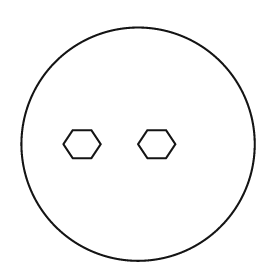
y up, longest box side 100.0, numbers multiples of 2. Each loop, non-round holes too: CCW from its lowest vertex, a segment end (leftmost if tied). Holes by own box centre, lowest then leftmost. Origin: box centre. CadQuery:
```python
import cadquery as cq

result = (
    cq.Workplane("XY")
    .moveTo(0.0, 0.0)
    .circle(50.0)
    .moveTo(-28.0, -6.0)
    .lineTo(-20.0, -6.0)
    .lineTo(-16.0, 0.0)
    .lineTo(-20.0, 6.0)
    .lineTo(-28.0, 6.0)
    .lineTo(-32.0, 0.0)
    .close()
    .moveTo(4.0, -6.0)
    .lineTo(12.0, -6.0)
    .lineTo(16.0, 0.0)
    .lineTo(12.0, 6.0)
    .lineTo(4.0, 6.0)
    .lineTo(0.0, 0.0)
    .close()
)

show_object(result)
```